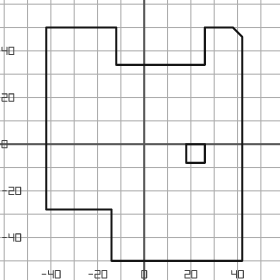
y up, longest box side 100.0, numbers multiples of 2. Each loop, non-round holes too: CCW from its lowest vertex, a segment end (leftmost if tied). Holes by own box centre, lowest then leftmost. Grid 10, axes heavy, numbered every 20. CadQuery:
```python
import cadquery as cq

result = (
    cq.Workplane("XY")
    .moveTo(-14.0, -50.0)
    .lineTo(42.0, -50.0)
    .lineTo(42.0, 46.0)
    .lineTo(38.0, 50.0)
    .lineTo(26.0, 50.0)
    .lineTo(26.0, 34.0)
    .lineTo(-12.0, 34.0)
    .lineTo(-12.0, 50.0)
    .lineTo(-42.0, 50.0)
    .lineTo(-42.0, -28.0)
    .lineTo(-14.0, -28.0)
    .close()
    .moveTo(18.0, -8.0)
    .lineTo(26.0, -8.0)
    .lineTo(26.0, 0.0)
    .lineTo(18.0, 0.0)
    .close()
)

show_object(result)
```